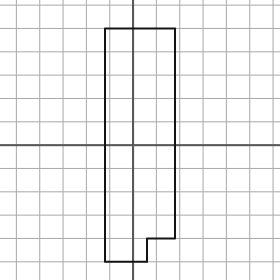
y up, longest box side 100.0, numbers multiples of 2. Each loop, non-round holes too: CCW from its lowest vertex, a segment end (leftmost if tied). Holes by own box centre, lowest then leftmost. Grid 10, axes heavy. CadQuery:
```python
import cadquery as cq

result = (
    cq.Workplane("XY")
    .moveTo(-12.0, -50.0)
    .lineTo(6.0, -50.0)
    .lineTo(6.0, -40.0)
    .lineTo(18.0, -40.0)
    .lineTo(18.0, 50.0)
    .lineTo(-12.0, 50.0)
    .close()
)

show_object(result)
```